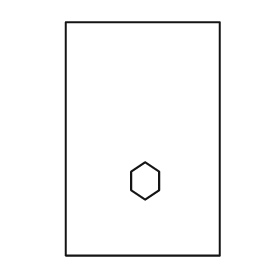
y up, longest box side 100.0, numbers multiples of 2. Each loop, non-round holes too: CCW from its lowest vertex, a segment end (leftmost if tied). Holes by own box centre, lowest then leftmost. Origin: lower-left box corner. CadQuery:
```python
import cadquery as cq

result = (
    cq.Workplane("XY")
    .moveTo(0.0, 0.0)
    .lineTo(66.0, 0.0)
    .lineTo(66.0, 100.0)
    .lineTo(0.0, 100.0)
    .close()
    .moveTo(34.0, 24.0)
    .lineTo(40.0, 28.0)
    .lineTo(40.0, 36.0)
    .lineTo(34.0, 40.0)
    .lineTo(28.0, 36.0)
    .lineTo(28.0, 28.0)
    .close()
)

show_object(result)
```